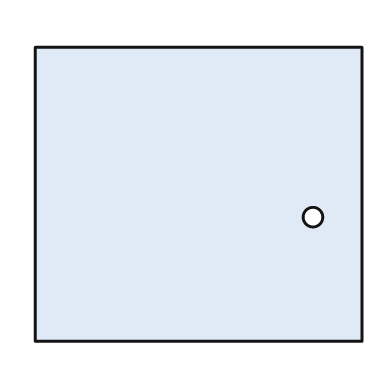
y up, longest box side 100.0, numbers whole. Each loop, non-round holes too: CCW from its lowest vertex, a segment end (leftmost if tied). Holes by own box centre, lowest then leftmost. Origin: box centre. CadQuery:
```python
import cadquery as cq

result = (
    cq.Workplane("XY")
    .moveTo(-50.0, -45.0)
    .lineTo(50.0, -45.0)
    .lineTo(50.0, 45.0)
    .lineTo(-50.0, 45.0)
    .close()
    .moveTo(35.0, -7.0)
    .circle(3.0)
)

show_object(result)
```